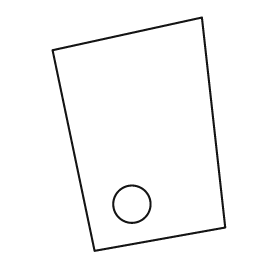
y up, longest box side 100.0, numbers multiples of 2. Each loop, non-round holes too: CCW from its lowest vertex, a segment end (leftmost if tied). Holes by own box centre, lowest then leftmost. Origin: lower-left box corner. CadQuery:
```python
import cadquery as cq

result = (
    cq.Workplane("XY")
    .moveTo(18.0, 0.0)
    .lineTo(74.0, 10.0)
    .lineTo(64.0, 100.0)
    .lineTo(0.0, 86.0)
    .close()
    .moveTo(34.0, 20.0)
    .circle(8.0)
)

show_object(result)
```